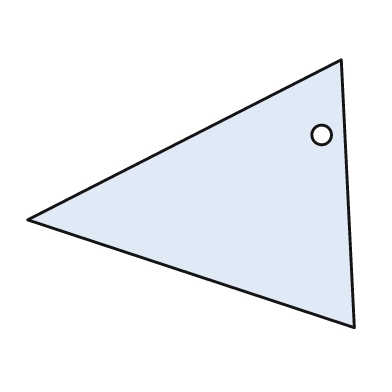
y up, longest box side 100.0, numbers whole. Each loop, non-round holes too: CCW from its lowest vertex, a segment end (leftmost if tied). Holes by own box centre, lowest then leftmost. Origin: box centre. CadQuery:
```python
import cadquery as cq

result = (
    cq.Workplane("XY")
    .moveTo(50.0, -41.0)
    .lineTo(46.0, 41.0)
    .lineTo(-50.0, -8.0)
    .close()
    .moveTo(40.0, 18.0)
    .circle(3.0)
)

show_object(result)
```